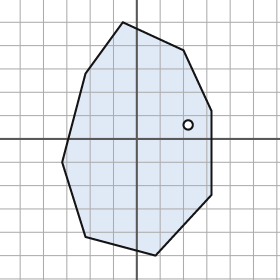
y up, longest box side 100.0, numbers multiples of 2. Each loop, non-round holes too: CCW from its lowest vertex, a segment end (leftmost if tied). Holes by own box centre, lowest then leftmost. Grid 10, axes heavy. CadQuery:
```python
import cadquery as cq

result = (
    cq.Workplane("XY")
    .moveTo(8.0, -50.0)
    .lineTo(32.0, -24.0)
    .lineTo(32.0, 12.0)
    .lineTo(20.0, 38.0)
    .lineTo(-6.0, 50.0)
    .lineTo(-22.0, 28.0)
    .lineTo(-32.0, -10.0)
    .lineTo(-22.0, -42.0)
    .close()
    .moveTo(22.0, 6.0)
    .circle(2.0)
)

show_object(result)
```